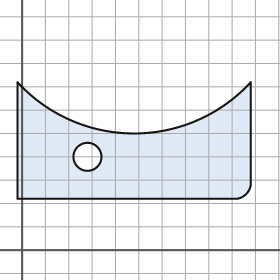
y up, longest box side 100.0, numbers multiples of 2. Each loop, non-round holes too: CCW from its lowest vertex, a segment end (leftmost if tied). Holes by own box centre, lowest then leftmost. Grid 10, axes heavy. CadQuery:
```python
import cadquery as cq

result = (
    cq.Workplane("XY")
    .moveTo(-2.0, 22.0)
    .lineTo(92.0, 22.0)
    .threePointArc((96.0, 24.0), (98.0, 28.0))
    .lineTo(98.0, 72.0)
    .threePointArc((48.0, 50.0), (-2.0, 72.0))
    .close()
    .moveTo(28.0, 40.0)
    .circle(6.0)
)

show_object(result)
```